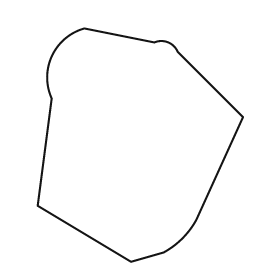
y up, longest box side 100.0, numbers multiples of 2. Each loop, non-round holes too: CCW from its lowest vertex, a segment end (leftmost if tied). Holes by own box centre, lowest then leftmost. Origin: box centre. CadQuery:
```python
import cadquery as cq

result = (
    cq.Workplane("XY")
    .moveTo(-4.0, -50.0)
    .lineTo(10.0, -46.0)
    .threePointArc((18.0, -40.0), (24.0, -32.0))
    .lineTo(44.0, 12.0)
    .lineTo(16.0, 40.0)
    .threePointArc((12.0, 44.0), (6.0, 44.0))
    .lineTo(-24.0, 50.0)
    .threePointArc((-38.0, 38.0), (-38.0, 20.0))
    .lineTo(-44.0, -26.0)
    .close()
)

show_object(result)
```